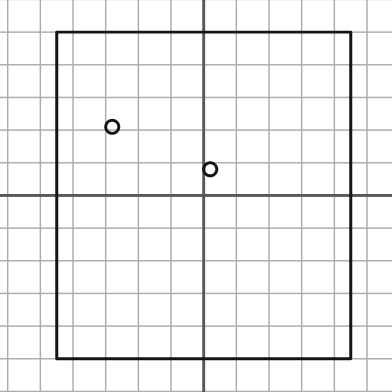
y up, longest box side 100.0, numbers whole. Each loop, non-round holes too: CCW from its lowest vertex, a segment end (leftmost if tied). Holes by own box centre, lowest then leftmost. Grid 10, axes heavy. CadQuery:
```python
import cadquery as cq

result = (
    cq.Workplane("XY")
    .moveTo(-45.0, -50.0)
    .lineTo(45.0, -50.0)
    .lineTo(45.0, 50.0)
    .lineTo(-45.0, 50.0)
    .close()
    .moveTo(2.0, 8.0)
    .circle(2.0)
    .moveTo(-28.0, 21.0)
    .circle(2.0)
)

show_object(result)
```